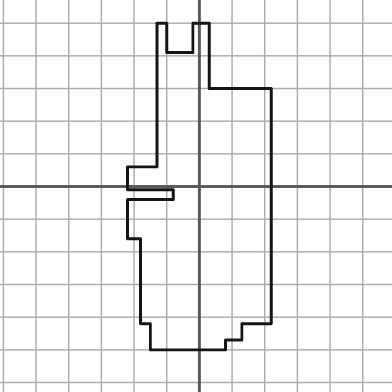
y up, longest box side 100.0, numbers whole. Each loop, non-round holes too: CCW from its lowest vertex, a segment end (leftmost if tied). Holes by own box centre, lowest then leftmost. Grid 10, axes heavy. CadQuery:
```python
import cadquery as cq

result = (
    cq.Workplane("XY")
    .moveTo(-15.0, -50.0)
    .lineTo(8.0, -50.0)
    .lineTo(8.0, -47.0)
    .lineTo(13.0, -47.0)
    .lineTo(13.0, -42.0)
    .lineTo(22.0, -42.0)
    .lineTo(22.0, 30.0)
    .lineTo(3.0, 30.0)
    .lineTo(3.0, 50.0)
    .lineTo(-2.0, 50.0)
    .lineTo(-2.0, 41.0)
    .lineTo(-10.0, 41.0)
    .lineTo(-10.0, 50.0)
    .lineTo(-13.0, 50.0)
    .lineTo(-13.0, 6.0)
    .lineTo(-22.0, 6.0)
    .lineTo(-22.0, -1.0)
    .lineTo(-8.0, -1.0)
    .lineTo(-8.0, -4.0)
    .lineTo(-22.0, -4.0)
    .lineTo(-22.0, -16.0)
    .lineTo(-18.0, -16.0)
    .lineTo(-18.0, -42.0)
    .lineTo(-15.0, -42.0)
    .close()
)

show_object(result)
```